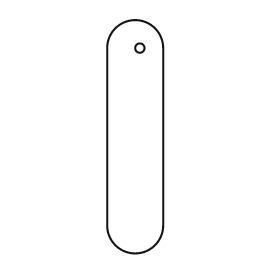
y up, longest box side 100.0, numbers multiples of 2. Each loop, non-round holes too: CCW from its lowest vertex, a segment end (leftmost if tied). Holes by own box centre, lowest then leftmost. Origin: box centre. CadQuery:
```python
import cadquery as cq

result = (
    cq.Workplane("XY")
    .moveTo(-12.0, -38.0)
    .threePointArc((0.0, -50.0), (12.0, -38.0))
    .lineTo(12.0, 38.0)
    .threePointArc((0.0, 50.0), (-12.0, 38.0))
    .close()
    .moveTo(2.0, 38.0)
    .circle(2.0)
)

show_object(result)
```